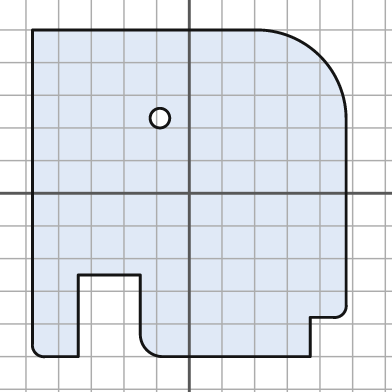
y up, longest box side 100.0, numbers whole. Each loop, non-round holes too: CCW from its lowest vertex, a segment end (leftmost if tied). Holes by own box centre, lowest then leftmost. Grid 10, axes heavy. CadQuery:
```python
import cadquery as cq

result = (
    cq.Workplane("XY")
    .moveTo(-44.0, -50.0)
    .lineTo(-34.0, -50.0)
    .lineTo(-34.0, -25.0)
    .lineTo(-15.0, -25.0)
    .lineTo(-15.0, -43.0)
    .threePointArc((-13.0, -48.0), (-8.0, -50.0))
    .lineTo(37.0, -50.0)
    .lineTo(37.0, -38.0)
    .lineTo(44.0, -38.0)
    .threePointArc((47.0, -37.0), (48.0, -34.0))
    .lineTo(48.0, 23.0)
    .threePointArc((40.0, 42.0), (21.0, 50.0))
    .lineTo(-48.0, 50.0)
    .lineTo(-48.0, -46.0)
    .threePointArc((-47.0, -49.0), (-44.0, -50.0))
    .close()
    .moveTo(-9.0, 23.0)
    .circle(3.0)
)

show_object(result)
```